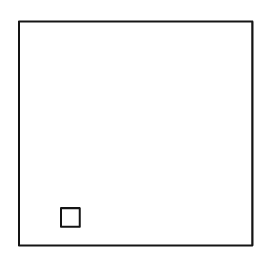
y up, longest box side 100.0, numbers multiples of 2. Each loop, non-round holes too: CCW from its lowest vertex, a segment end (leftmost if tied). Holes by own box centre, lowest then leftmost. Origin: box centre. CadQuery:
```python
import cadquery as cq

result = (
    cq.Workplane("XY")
    .moveTo(-50.0, -48.0)
    .lineTo(50.0, -48.0)
    .lineTo(50.0, 48.0)
    .lineTo(-50.0, 48.0)
    .close()
    .moveTo(-32.0, -40.0)
    .lineTo(-24.0, -40.0)
    .lineTo(-24.0, -32.0)
    .lineTo(-32.0, -32.0)
    .close()
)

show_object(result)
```